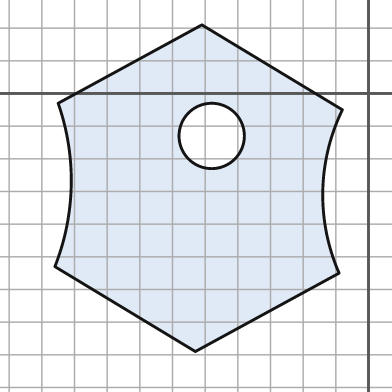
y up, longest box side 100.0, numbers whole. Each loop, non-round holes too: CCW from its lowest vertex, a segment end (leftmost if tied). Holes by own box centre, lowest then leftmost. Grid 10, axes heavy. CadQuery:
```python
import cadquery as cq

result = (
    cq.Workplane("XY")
    .moveTo(-53.0, -79.0)
    .lineTo(-9.0, -55.0)
    .threePointArc((-14.0, -30.0), (-8.0, -5.0))
    .lineTo(-51.0, 21.0)
    .lineTo(-95.0, -3.0)
    .threePointArc((-91.0, -28.0), (-96.0, -53.0))
    .close()
    .moveTo(-48.0, -13.0)
    .circle(10.0)
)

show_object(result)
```